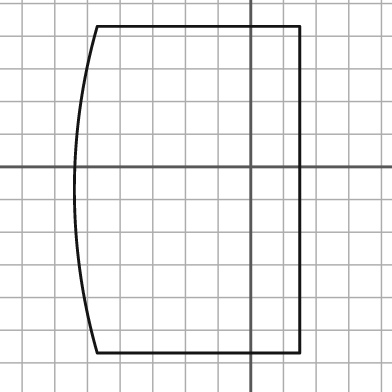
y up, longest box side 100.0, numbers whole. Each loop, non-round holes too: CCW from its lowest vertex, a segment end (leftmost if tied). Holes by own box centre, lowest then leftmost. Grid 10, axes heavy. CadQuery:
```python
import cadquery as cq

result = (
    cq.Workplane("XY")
    .moveTo(-47.0, -57.0)
    .lineTo(15.0, -57.0)
    .lineTo(15.0, 43.0)
    .lineTo(-47.0, 43.0)
    .threePointArc((-54.0, -7.0), (-47.0, -57.0))
    .close()
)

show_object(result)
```